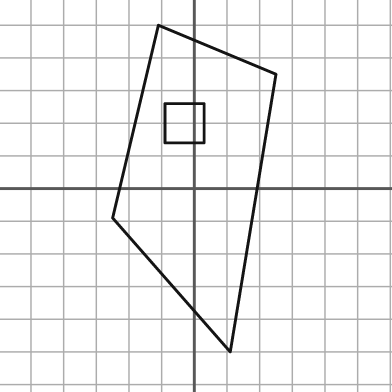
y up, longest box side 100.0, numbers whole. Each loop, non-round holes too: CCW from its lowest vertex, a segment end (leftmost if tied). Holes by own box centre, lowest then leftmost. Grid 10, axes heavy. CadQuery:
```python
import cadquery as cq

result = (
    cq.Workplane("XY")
    .moveTo(11.0, -50.0)
    .lineTo(25.0, 35.0)
    .lineTo(-11.0, 50.0)
    .lineTo(-25.0, -9.0)
    .close()
    .moveTo(-9.0, 14.0)
    .lineTo(3.0, 14.0)
    .lineTo(3.0, 26.0)
    .lineTo(-9.0, 26.0)
    .close()
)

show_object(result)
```